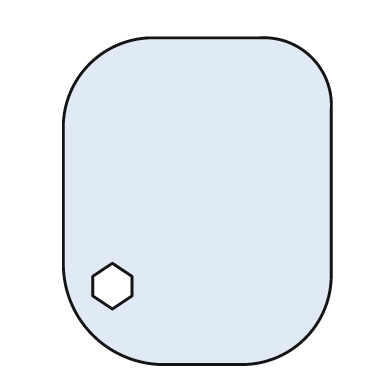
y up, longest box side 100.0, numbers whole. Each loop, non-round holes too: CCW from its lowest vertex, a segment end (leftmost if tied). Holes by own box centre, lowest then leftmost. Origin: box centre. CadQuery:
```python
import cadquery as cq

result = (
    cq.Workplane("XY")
    .moveTo(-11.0, -50.0)
    .lineTo(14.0, -50.0)
    .threePointArc((33.0, -42.0), (41.0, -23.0))
    .lineTo(41.0, 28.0)
    .threePointArc((35.0, 44.0), (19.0, 50.0))
    .lineTo(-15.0, 50.0)
    .threePointArc((-33.0, 42.0), (-41.0, 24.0))
    .lineTo(-41.0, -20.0)
    .threePointArc((-32.0, -41.0), (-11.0, -50.0))
    .close()
    .moveTo(-26.0, -33.0)
    .lineTo(-20.0, -29.0)
    .lineTo(-20.0, -23.0)
    .lineTo(-26.0, -19.0)
    .lineTo(-32.0, -23.0)
    .lineTo(-32.0, -29.0)
    .close()
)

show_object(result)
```